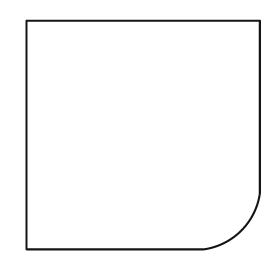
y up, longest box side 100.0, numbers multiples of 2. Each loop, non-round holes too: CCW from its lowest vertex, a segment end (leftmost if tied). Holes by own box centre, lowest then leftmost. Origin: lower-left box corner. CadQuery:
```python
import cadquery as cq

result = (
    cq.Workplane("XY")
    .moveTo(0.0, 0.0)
    .lineTo(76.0, 0.0)
    .threePointArc((92.0, 8.0), (100.0, 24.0))
    .lineTo(100.0, 98.0)
    .lineTo(0.0, 98.0)
    .close()
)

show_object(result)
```